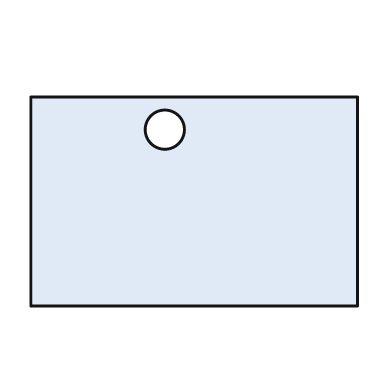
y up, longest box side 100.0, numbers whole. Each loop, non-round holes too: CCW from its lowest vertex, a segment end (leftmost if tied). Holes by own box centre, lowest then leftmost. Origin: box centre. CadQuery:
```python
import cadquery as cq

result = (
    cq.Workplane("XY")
    .moveTo(-50.0, -32.0)
    .lineTo(50.0, -32.0)
    .lineTo(50.0, 32.0)
    .lineTo(-50.0, 32.0)
    .close()
    .moveTo(-9.0, 22.0)
    .circle(6.0)
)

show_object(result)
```